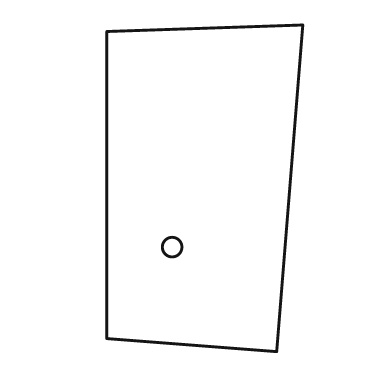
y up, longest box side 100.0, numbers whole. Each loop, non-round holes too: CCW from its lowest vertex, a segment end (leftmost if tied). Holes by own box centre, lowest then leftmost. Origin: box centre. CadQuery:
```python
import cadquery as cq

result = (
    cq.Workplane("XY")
    .moveTo(22.0, -50.0)
    .lineTo(30.0, 50.0)
    .lineTo(-30.0, 48.0)
    .lineTo(-30.0, -46.0)
    .close()
    .moveTo(-10.0, -18.0)
    .circle(3.0)
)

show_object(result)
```